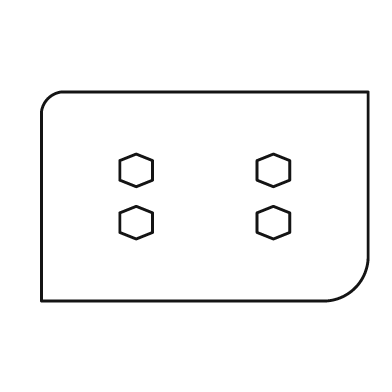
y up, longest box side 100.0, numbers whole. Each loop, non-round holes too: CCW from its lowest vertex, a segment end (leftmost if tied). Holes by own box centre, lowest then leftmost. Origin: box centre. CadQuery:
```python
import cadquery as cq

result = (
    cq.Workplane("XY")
    .moveTo(-50.0, -32.0)
    .lineTo(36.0, -32.0)
    .threePointArc((46.0, -28.0), (50.0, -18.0))
    .lineTo(50.0, 32.0)
    .lineTo(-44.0, 32.0)
    .threePointArc((-48.0, 30.0), (-50.0, 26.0))
    .close()
    .moveTo(-21.0, -13.0)
    .lineTo(-16.0, -11.0)
    .lineTo(-16.0, -5.0)
    .lineTo(-21.0, -3.0)
    .lineTo(-26.0, -5.0)
    .lineTo(-26.0, -11.0)
    .close()
    .moveTo(21.0, -13.0)
    .lineTo(26.0, -11.0)
    .lineTo(26.0, -5.0)
    .lineTo(21.0, -3.0)
    .lineTo(16.0, -5.0)
    .lineTo(16.0, -11.0)
    .close()
    .moveTo(-21.0, 3.0)
    .lineTo(-16.0, 5.0)
    .lineTo(-16.0, 11.0)
    .lineTo(-21.0, 13.0)
    .lineTo(-26.0, 11.0)
    .lineTo(-26.0, 5.0)
    .close()
    .moveTo(21.0, 3.0)
    .lineTo(26.0, 5.0)
    .lineTo(26.0, 11.0)
    .lineTo(21.0, 13.0)
    .lineTo(16.0, 11.0)
    .lineTo(16.0, 5.0)
    .close()
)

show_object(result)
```